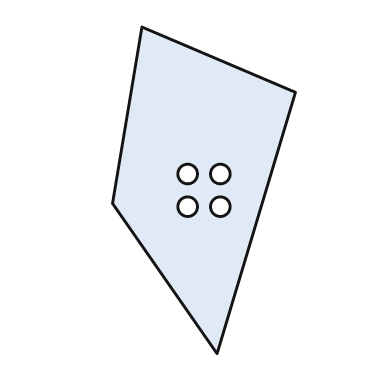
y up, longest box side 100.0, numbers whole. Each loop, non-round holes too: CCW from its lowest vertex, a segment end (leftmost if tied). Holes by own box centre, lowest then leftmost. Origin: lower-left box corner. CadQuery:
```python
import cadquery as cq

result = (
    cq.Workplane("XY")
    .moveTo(32.0, 0.0)
    .lineTo(56.0, 80.0)
    .lineTo(9.0, 100.0)
    .lineTo(0.0, 46.0)
    .close()
    .moveTo(23.0, 45.0)
    .circle(3.0)
    .moveTo(33.0, 45.0)
    .circle(3.0)
    .moveTo(23.0, 55.0)
    .circle(3.0)
    .moveTo(33.0, 55.0)
    .circle(3.0)
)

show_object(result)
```